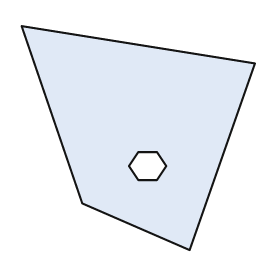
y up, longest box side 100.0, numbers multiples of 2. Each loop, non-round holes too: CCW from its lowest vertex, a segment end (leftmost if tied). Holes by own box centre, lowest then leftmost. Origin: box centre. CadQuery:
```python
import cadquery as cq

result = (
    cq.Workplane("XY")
    .moveTo(22.0, -48.0)
    .lineTo(50.0, 32.0)
    .lineTo(-50.0, 48.0)
    .lineTo(-24.0, -28.0)
    .close()
    .moveTo(0.0, -18.0)
    .lineTo(8.0, -18.0)
    .lineTo(12.0, -12.0)
    .lineTo(8.0, -6.0)
    .lineTo(0.0, -6.0)
    .lineTo(-4.0, -12.0)
    .close()
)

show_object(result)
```